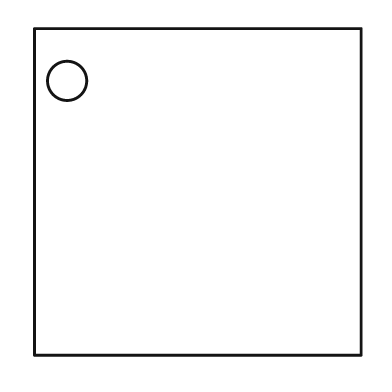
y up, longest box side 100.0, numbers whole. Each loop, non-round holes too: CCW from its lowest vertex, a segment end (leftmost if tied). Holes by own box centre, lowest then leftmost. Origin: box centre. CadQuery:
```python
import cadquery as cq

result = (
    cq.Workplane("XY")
    .moveTo(-50.0, -50.0)
    .lineTo(50.0, -50.0)
    .lineTo(50.0, 50.0)
    .lineTo(-50.0, 50.0)
    .close()
    .moveTo(-40.0, 34.0)
    .circle(6.0)
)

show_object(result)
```